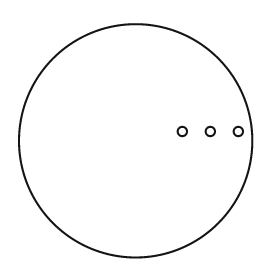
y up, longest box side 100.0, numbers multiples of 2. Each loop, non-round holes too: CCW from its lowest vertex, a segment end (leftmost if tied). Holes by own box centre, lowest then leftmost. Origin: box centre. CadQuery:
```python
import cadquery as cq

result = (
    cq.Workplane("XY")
    .moveTo(0.0, 0.0)
    .circle(50.0)
    .moveTo(20.0, 4.0)
    .circle(2.0)
    .moveTo(32.0, 4.0)
    .circle(2.0)
    .moveTo(44.0, 4.0)
    .circle(2.0)
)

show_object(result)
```